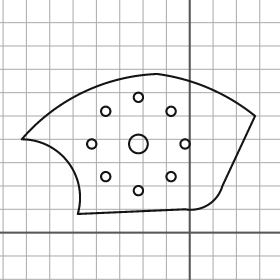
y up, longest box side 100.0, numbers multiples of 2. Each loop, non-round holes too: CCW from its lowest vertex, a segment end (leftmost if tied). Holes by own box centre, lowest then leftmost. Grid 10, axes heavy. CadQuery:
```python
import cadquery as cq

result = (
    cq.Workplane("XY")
    .moveTo(-48.0, 8.0)
    .lineTo(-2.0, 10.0)
    .threePointArc((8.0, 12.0), (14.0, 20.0))
    .lineTo(28.0, 50.0)
    .threePointArc((8.0, 62.0), (-14.0, 68.0))
    .threePointArc((-46.0, 60.0), (-72.0, 40.0))
    .threePointArc((-52.0, 30.0), (-48.0, 8.0))
    .close()
    .moveTo(-22.0, 18.0)
    .circle(2.0)
    .moveTo(-36.0, 24.0)
    .circle(2.0)
    .moveTo(-8.0, 24.0)
    .circle(2.0)
    .moveTo(-42.0, 38.0)
    .circle(2.0)
    .moveTo(-22.0, 38.0)
    .circle(4.0)
    .moveTo(-2.0, 38.0)
    .circle(2.0)
    .moveTo(-36.0, 52.0)
    .circle(2.0)
    .moveTo(-8.0, 52.0)
    .circle(2.0)
    .moveTo(-22.0, 58.0)
    .circle(2.0)
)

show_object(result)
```